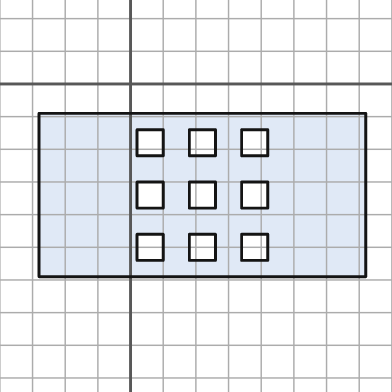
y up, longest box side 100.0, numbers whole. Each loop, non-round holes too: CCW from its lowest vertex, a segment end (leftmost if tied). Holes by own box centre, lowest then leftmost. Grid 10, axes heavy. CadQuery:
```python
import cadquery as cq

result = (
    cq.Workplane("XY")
    .moveTo(-28.0, -59.0)
    .lineTo(72.0, -59.0)
    .lineTo(72.0, -9.0)
    .lineTo(-28.0, -9.0)
    .close()
    .moveTo(2.0, -54.0)
    .lineTo(10.0, -54.0)
    .lineTo(10.0, -46.0)
    .lineTo(2.0, -46.0)
    .close()
    .moveTo(18.0, -54.0)
    .lineTo(26.0, -54.0)
    .lineTo(26.0, -46.0)
    .lineTo(18.0, -46.0)
    .close()
    .moveTo(34.0, -54.0)
    .lineTo(42.0, -54.0)
    .lineTo(42.0, -46.0)
    .lineTo(34.0, -46.0)
    .close()
    .moveTo(2.0, -38.0)
    .lineTo(10.0, -38.0)
    .lineTo(10.0, -30.0)
    .lineTo(2.0, -30.0)
    .close()
    .moveTo(18.0, -38.0)
    .lineTo(26.0, -38.0)
    .lineTo(26.0, -30.0)
    .lineTo(18.0, -30.0)
    .close()
    .moveTo(34.0, -38.0)
    .lineTo(42.0, -38.0)
    .lineTo(42.0, -30.0)
    .lineTo(34.0, -30.0)
    .close()
    .moveTo(2.0, -22.0)
    .lineTo(10.0, -22.0)
    .lineTo(10.0, -14.0)
    .lineTo(2.0, -14.0)
    .close()
    .moveTo(18.0, -22.0)
    .lineTo(26.0, -22.0)
    .lineTo(26.0, -14.0)
    .lineTo(18.0, -14.0)
    .close()
    .moveTo(34.0, -22.0)
    .lineTo(42.0, -22.0)
    .lineTo(42.0, -14.0)
    .lineTo(34.0, -14.0)
    .close()
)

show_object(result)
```